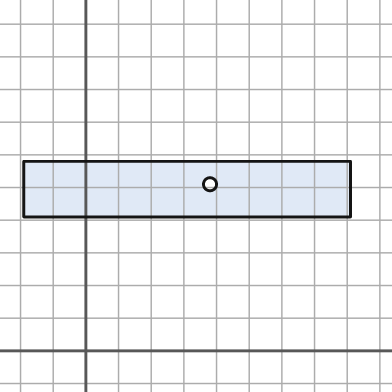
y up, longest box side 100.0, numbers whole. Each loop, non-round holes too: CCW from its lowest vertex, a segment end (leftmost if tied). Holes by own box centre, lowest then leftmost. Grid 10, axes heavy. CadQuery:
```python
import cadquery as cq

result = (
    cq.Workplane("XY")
    .moveTo(-19.0, 41.0)
    .lineTo(81.0, 41.0)
    .lineTo(81.0, 58.0)
    .lineTo(-19.0, 58.0)
    .close()
    .moveTo(38.0, 51.0)
    .circle(2.0)
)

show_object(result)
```